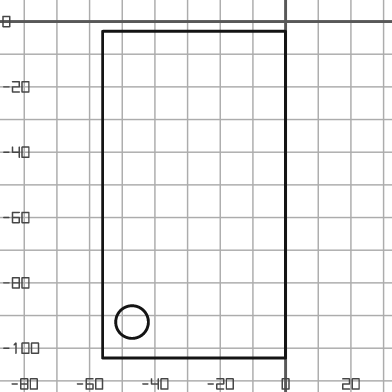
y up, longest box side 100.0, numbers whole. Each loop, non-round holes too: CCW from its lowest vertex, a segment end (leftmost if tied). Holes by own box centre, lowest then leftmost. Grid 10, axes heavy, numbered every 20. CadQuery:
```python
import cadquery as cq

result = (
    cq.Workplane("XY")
    .moveTo(-56.0, -103.0)
    .lineTo(0.0, -103.0)
    .lineTo(0.0, -3.0)
    .lineTo(-56.0, -3.0)
    .close()
    .moveTo(-47.0, -92.0)
    .circle(5.0)
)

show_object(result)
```